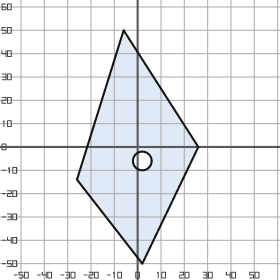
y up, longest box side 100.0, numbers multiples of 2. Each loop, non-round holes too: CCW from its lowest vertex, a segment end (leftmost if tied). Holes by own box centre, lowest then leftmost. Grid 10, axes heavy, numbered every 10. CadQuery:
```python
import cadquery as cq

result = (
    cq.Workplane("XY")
    .moveTo(2.0, -50.0)
    .lineTo(26.0, 0.0)
    .lineTo(-6.0, 50.0)
    .lineTo(-26.0, -14.0)
    .close()
    .moveTo(2.0, -6.0)
    .circle(4.0)
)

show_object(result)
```